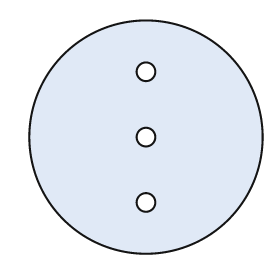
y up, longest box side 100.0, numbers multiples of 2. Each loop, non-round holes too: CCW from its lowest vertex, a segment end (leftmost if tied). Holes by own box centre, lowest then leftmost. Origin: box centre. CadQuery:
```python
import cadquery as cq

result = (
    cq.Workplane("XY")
    .moveTo(0.0, 0.0)
    .circle(50.0)
    .moveTo(0.0, -28.0)
    .circle(4.0)
    .moveTo(0.0, 0.0)
    .circle(4.0)
    .moveTo(0.0, 28.0)
    .circle(4.0)
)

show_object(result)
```